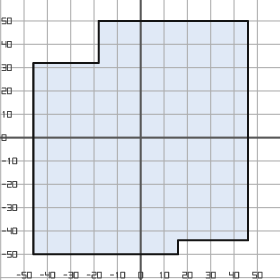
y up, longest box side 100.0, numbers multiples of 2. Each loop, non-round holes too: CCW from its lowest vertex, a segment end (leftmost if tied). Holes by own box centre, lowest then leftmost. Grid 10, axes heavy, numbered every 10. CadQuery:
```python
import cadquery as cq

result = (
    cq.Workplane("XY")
    .moveTo(-46.0, -50.0)
    .lineTo(16.0, -50.0)
    .lineTo(16.0, -44.0)
    .lineTo(46.0, -44.0)
    .lineTo(46.0, 50.0)
    .lineTo(-18.0, 50.0)
    .lineTo(-18.0, 32.0)
    .lineTo(-46.0, 32.0)
    .close()
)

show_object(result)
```